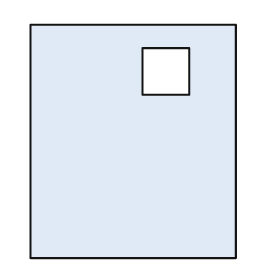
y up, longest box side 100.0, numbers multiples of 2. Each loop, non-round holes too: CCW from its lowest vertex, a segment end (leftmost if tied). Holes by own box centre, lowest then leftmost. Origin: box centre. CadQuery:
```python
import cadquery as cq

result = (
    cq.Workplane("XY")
    .moveTo(-44.0, -50.0)
    .lineTo(44.0, -50.0)
    .lineTo(44.0, 50.0)
    .lineTo(-44.0, 50.0)
    .close()
    .moveTo(4.0, 20.0)
    .lineTo(24.0, 20.0)
    .lineTo(24.0, 40.0)
    .lineTo(4.0, 40.0)
    .close()
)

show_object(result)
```